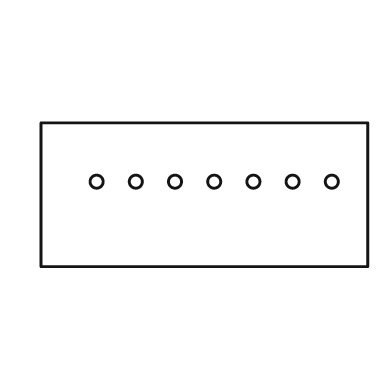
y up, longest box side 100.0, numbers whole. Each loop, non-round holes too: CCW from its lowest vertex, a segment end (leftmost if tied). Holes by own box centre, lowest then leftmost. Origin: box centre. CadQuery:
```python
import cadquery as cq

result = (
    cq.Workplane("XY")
    .moveTo(-50.0, -22.0)
    .lineTo(50.0, -22.0)
    .lineTo(50.0, 22.0)
    .lineTo(-50.0, 22.0)
    .close()
    .moveTo(-33.0, 4.0)
    .circle(2.0)
    .moveTo(-21.0, 4.0)
    .circle(2.0)
    .moveTo(-9.0, 4.0)
    .circle(2.0)
    .moveTo(3.0, 4.0)
    .circle(2.0)
    .moveTo(15.0, 4.0)
    .circle(2.0)
    .moveTo(27.0, 4.0)
    .circle(2.0)
    .moveTo(39.0, 4.0)
    .circle(2.0)
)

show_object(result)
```